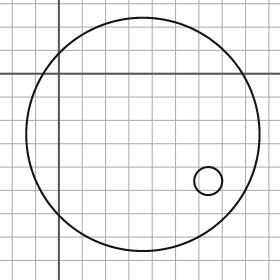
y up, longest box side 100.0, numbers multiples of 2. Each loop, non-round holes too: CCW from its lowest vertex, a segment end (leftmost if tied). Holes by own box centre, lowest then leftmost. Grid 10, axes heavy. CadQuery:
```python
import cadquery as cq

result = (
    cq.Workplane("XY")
    .moveTo(36.0, -26.0)
    .circle(50.0)
    .moveTo(64.0, -46.0)
    .circle(6.0)
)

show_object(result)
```